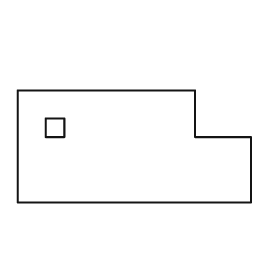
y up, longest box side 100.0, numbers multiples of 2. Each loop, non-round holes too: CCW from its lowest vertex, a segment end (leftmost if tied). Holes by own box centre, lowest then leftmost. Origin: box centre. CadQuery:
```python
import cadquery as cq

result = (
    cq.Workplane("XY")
    .moveTo(-50.0, -24.0)
    .lineTo(50.0, -24.0)
    .lineTo(50.0, 4.0)
    .lineTo(26.0, 4.0)
    .lineTo(26.0, 24.0)
    .lineTo(-50.0, 24.0)
    .close()
    .moveTo(-38.0, 4.0)
    .lineTo(-30.0, 4.0)
    .lineTo(-30.0, 12.0)
    .lineTo(-38.0, 12.0)
    .close()
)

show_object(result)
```